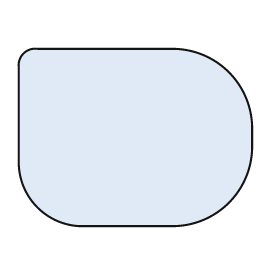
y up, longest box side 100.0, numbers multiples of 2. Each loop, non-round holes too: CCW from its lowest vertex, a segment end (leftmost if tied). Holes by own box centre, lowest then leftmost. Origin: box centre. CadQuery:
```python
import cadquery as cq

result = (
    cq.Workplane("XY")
    .moveTo(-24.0, -38.0)
    .lineTo(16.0, -38.0)
    .threePointArc((40.0, -28.0), (50.0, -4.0))
    .lineTo(50.0, 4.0)
    .threePointArc((40.0, 28.0), (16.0, 38.0))
    .lineTo(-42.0, 38.0)
    .threePointArc((-48.0, 36.0), (-50.0, 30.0))
    .lineTo(-50.0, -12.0)
    .threePointArc((-42.0, -30.0), (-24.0, -38.0))
    .close()
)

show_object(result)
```